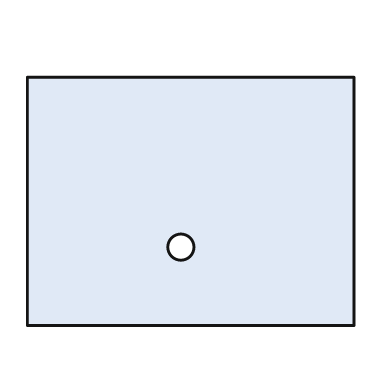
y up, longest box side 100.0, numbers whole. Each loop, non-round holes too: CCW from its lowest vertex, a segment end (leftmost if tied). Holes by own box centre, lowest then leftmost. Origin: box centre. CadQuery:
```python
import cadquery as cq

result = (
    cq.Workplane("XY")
    .moveTo(-50.0, -38.0)
    .lineTo(50.0, -38.0)
    .lineTo(50.0, 38.0)
    .lineTo(-50.0, 38.0)
    .close()
    .moveTo(-3.0, -14.0)
    .circle(4.0)
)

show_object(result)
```